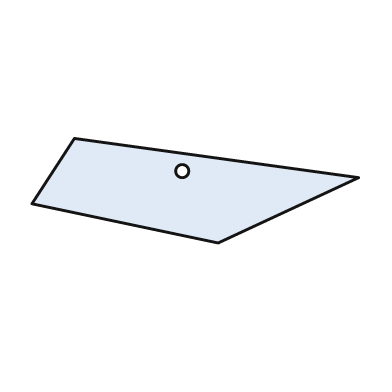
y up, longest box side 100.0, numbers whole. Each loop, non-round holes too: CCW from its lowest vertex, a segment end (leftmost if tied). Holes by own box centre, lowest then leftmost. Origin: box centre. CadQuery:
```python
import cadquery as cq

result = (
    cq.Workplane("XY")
    .moveTo(7.0, -16.0)
    .lineTo(50.0, 4.0)
    .lineTo(-37.0, 16.0)
    .lineTo(-50.0, -4.0)
    .close()
    .moveTo(-4.0, 6.0)
    .circle(2.0)
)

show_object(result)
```